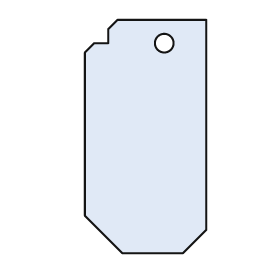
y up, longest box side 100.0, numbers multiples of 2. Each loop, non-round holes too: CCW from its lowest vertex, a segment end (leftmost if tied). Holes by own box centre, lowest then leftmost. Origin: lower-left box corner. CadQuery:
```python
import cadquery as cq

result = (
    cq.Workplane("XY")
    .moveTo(16.0, 0.0)
    .lineTo(42.0, 0.0)
    .lineTo(52.0, 10.0)
    .lineTo(52.0, 100.0)
    .lineTo(14.0, 100.0)
    .lineTo(10.0, 96.0)
    .lineTo(10.0, 90.0)
    .lineTo(4.0, 90.0)
    .lineTo(0.0, 86.0)
    .lineTo(0.0, 16.0)
    .close()
    .moveTo(34.0, 90.0)
    .circle(4.0)
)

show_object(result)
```